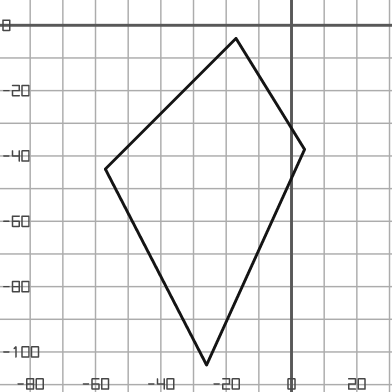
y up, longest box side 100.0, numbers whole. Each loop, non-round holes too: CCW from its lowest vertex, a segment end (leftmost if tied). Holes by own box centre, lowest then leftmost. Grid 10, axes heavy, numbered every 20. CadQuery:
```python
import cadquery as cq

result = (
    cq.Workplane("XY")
    .moveTo(-26.0, -104.0)
    .lineTo(4.0, -38.0)
    .lineTo(-17.0, -4.0)
    .lineTo(-57.0, -44.0)
    .close()
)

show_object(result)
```